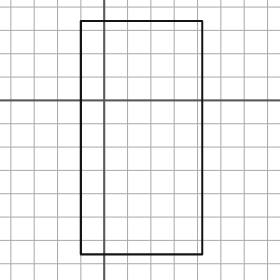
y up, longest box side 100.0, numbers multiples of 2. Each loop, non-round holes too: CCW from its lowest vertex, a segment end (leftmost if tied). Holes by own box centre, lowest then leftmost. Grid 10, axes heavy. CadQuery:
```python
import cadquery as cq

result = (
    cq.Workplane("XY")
    .moveTo(-10.0, -66.0)
    .lineTo(42.0, -66.0)
    .lineTo(42.0, 34.0)
    .lineTo(-10.0, 34.0)
    .close()
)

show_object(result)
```